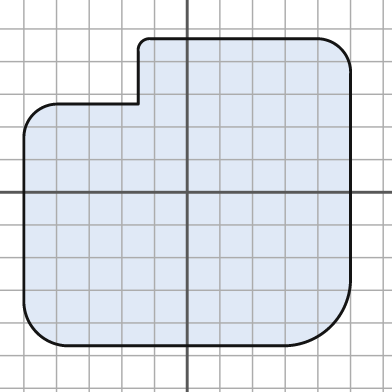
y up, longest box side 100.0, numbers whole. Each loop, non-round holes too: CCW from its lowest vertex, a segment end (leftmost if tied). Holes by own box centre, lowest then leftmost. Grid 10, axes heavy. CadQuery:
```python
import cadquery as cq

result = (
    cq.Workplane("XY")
    .moveTo(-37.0, -47.0)
    .lineTo(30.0, -47.0)
    .threePointArc((44.0, -41.0), (50.0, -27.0))
    .lineTo(50.0, 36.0)
    .threePointArc((47.0, 44.0), (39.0, 47.0))
    .lineTo(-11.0, 47.0)
    .threePointArc((-14.0, 46.0), (-15.0, 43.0))
    .lineTo(-15.0, 27.0)
    .lineTo(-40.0, 27.0)
    .threePointArc((-47.0, 24.0), (-50.0, 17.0))
    .lineTo(-50.0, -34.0)
    .threePointArc((-46.0, -43.0), (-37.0, -47.0))
    .close()
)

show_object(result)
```